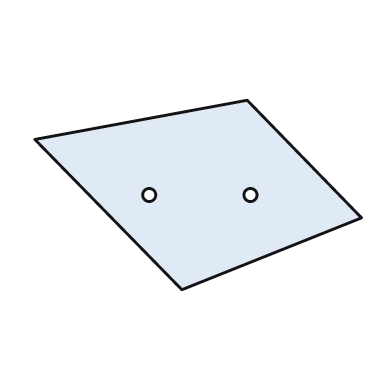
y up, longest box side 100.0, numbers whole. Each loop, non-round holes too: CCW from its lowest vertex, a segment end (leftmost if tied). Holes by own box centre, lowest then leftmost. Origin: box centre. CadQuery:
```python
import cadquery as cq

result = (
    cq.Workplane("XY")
    .moveTo(-5.0, -29.0)
    .lineTo(50.0, -7.0)
    .lineTo(15.0, 29.0)
    .lineTo(-50.0, 17.0)
    .close()
    .moveTo(-15.0, 0.0)
    .circle(2.0)
    .moveTo(16.0, 0.0)
    .circle(2.0)
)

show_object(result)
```